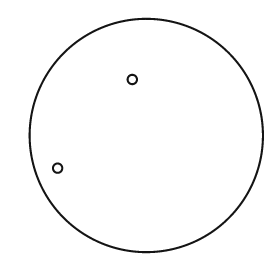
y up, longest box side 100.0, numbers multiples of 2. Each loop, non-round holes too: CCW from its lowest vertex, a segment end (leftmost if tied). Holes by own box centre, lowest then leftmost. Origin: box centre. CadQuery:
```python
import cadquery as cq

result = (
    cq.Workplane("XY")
    .moveTo(0.0, 0.0)
    .circle(50.0)
    .moveTo(-38.0, -14.0)
    .circle(2.0)
    .moveTo(-6.0, 24.0)
    .circle(2.0)
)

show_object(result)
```